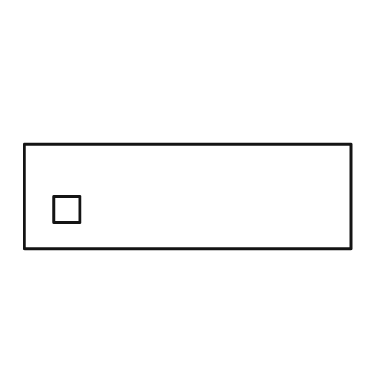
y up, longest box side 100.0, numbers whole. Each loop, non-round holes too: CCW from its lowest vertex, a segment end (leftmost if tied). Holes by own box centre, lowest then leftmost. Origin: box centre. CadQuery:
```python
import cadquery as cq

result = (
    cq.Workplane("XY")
    .moveTo(-50.0, -16.0)
    .lineTo(50.0, -16.0)
    .lineTo(50.0, 16.0)
    .lineTo(-50.0, 16.0)
    .close()
    .moveTo(-41.0, -8.0)
    .lineTo(-33.0, -8.0)
    .lineTo(-33.0, 0.0)
    .lineTo(-41.0, 0.0)
    .close()
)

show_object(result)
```